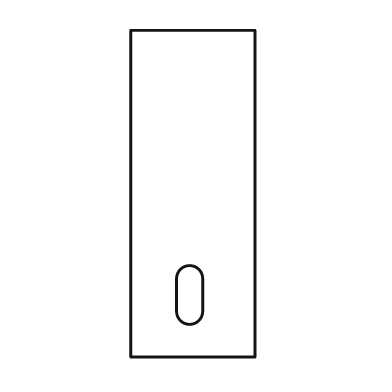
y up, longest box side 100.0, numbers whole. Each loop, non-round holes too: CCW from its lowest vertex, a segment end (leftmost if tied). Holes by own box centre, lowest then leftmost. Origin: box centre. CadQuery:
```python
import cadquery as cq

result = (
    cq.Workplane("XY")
    .moveTo(-19.0, -50.0)
    .lineTo(19.0, -50.0)
    .lineTo(19.0, 50.0)
    .lineTo(-19.0, 50.0)
    .close()
    .moveTo(-5.0, -36.0)
    .threePointArc((-1.0, -40.0), (3.0, -36.0))
    .lineTo(3.0, -26.0)
    .threePointArc((-1.0, -22.0), (-5.0, -26.0))
    .close()
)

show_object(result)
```